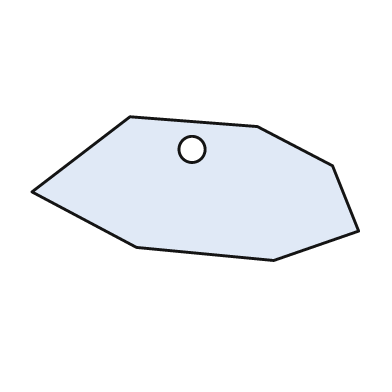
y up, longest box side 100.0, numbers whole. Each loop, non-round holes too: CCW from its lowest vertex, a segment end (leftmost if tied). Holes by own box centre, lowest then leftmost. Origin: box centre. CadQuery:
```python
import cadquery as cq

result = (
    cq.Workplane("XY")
    .moveTo(24.0, -22.0)
    .lineTo(50.0, -13.0)
    .lineTo(42.0, 7.0)
    .lineTo(19.0, 19.0)
    .lineTo(-20.0, 22.0)
    .lineTo(-50.0, -1.0)
    .lineTo(-18.0, -18.0)
    .close()
    .moveTo(-1.0, 12.0)
    .circle(4.0)
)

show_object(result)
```